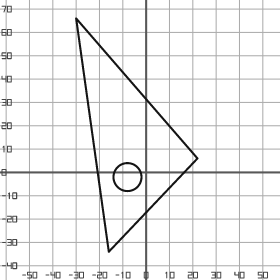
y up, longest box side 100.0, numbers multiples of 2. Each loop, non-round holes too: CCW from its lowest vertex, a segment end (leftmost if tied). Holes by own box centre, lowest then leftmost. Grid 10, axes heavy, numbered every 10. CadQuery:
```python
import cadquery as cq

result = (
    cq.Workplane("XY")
    .moveTo(-16.0, -34.0)
    .lineTo(22.0, 6.0)
    .lineTo(-30.0, 66.0)
    .close()
    .moveTo(-8.0, -2.0)
    .circle(6.0)
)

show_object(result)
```